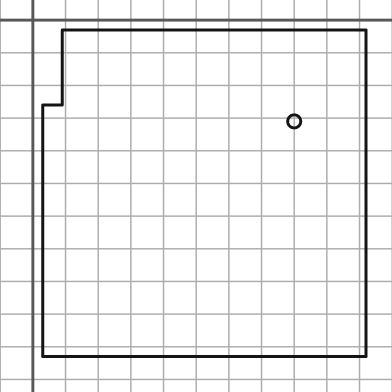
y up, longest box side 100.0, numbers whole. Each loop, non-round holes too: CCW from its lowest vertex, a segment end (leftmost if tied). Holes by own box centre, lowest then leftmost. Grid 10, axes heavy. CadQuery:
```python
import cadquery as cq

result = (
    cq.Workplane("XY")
    .moveTo(3.0, -103.0)
    .lineTo(102.0, -103.0)
    .lineTo(102.0, -3.0)
    .lineTo(9.0, -3.0)
    .lineTo(9.0, -26.0)
    .lineTo(3.0, -26.0)
    .close()
    .moveTo(80.0, -31.0)
    .circle(2.0)
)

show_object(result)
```